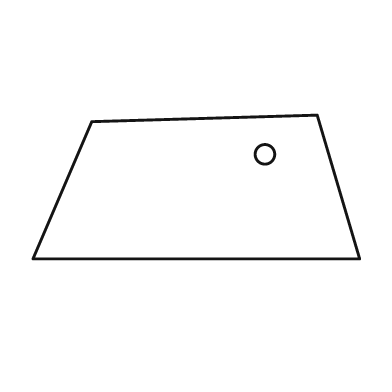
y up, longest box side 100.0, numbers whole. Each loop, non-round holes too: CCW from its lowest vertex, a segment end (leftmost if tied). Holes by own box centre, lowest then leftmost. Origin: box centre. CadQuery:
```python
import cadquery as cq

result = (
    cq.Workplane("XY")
    .moveTo(-50.0, -22.0)
    .lineTo(50.0, -22.0)
    .lineTo(37.0, 22.0)
    .lineTo(-32.0, 20.0)
    .close()
    .moveTo(21.0, 10.0)
    .circle(3.0)
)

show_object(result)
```